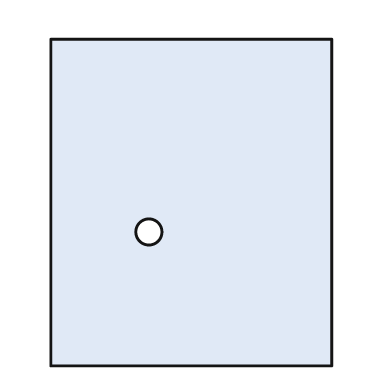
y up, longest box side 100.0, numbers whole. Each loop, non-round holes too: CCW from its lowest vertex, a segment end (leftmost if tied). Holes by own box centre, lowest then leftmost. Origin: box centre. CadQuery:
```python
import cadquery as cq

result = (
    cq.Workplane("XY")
    .moveTo(-43.0, -50.0)
    .lineTo(43.0, -50.0)
    .lineTo(43.0, 50.0)
    .lineTo(-43.0, 50.0)
    .close()
    .moveTo(-13.0, -9.0)
    .circle(4.0)
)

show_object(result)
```